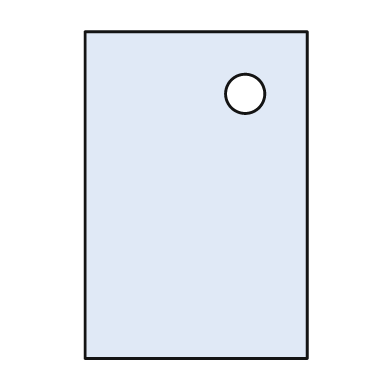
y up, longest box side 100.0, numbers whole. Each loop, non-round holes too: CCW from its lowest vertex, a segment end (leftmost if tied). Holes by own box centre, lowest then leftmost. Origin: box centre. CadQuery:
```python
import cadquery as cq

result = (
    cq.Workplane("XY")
    .moveTo(-34.0, -50.0)
    .lineTo(34.0, -50.0)
    .lineTo(34.0, 50.0)
    .lineTo(-34.0, 50.0)
    .close()
    .moveTo(15.0, 31.0)
    .circle(6.0)
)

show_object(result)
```